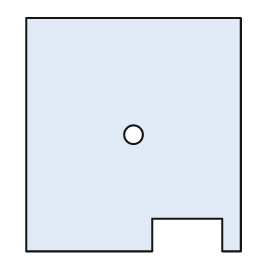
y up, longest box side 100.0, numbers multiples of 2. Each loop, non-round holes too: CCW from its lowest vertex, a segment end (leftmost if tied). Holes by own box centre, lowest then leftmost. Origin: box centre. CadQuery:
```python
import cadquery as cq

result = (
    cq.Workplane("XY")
    .moveTo(-46.0, -50.0)
    .lineTo(8.0, -50.0)
    .lineTo(8.0, -36.0)
    .lineTo(38.0, -36.0)
    .lineTo(38.0, -50.0)
    .lineTo(46.0, -50.0)
    .lineTo(46.0, 50.0)
    .lineTo(-46.0, 50.0)
    .close()
    .moveTo(0.0, 0.0)
    .circle(4.0)
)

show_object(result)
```